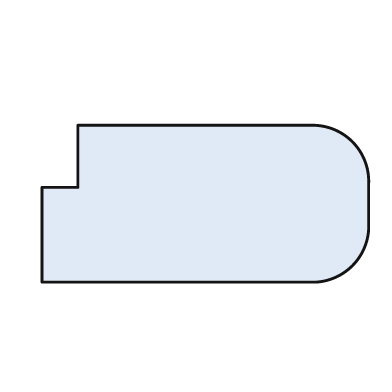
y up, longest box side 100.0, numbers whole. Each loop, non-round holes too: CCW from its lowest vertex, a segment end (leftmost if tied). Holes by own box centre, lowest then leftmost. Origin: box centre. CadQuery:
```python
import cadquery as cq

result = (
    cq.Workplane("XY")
    .moveTo(-50.0, -24.0)
    .lineTo(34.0, -24.0)
    .threePointArc((45.0, -19.0), (50.0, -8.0))
    .lineTo(50.0, 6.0)
    .threePointArc((45.0, 19.0), (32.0, 24.0))
    .lineTo(-39.0, 24.0)
    .lineTo(-39.0, 5.0)
    .lineTo(-50.0, 5.0)
    .close()
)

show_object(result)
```